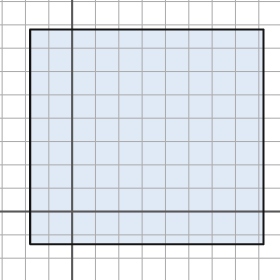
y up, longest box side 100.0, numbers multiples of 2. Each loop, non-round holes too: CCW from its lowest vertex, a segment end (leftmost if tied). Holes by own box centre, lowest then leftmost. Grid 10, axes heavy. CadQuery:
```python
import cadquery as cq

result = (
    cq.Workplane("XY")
    .moveTo(-18.0, -14.0)
    .lineTo(82.0, -14.0)
    .lineTo(82.0, 78.0)
    .lineTo(-18.0, 78.0)
    .close()
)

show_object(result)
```